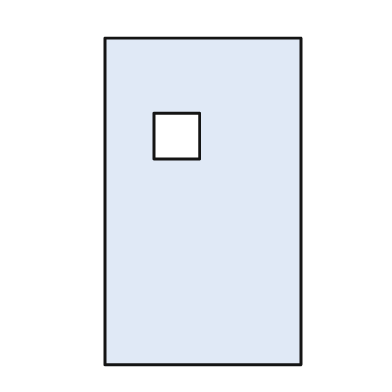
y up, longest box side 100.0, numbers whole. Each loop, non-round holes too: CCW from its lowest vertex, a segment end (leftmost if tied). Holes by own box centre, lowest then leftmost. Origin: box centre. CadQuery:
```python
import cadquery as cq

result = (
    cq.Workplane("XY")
    .moveTo(-30.0, -50.0)
    .lineTo(30.0, -50.0)
    .lineTo(30.0, 50.0)
    .lineTo(-30.0, 50.0)
    .close()
    .moveTo(-15.0, 13.0)
    .lineTo(-1.0, 13.0)
    .lineTo(-1.0, 27.0)
    .lineTo(-15.0, 27.0)
    .close()
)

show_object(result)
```